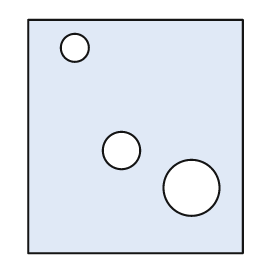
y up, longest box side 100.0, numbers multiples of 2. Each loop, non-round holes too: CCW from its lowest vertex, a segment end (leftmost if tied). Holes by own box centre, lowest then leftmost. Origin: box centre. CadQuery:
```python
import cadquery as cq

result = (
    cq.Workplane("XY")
    .moveTo(-46.0, -50.0)
    .lineTo(46.0, -50.0)
    .lineTo(46.0, 50.0)
    .lineTo(-46.0, 50.0)
    .close()
    .moveTo(24.0, -22.0)
    .circle(12.0)
    .moveTo(-6.0, -6.0)
    .circle(8.0)
    .moveTo(-26.0, 38.0)
    .circle(6.0)
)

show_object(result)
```